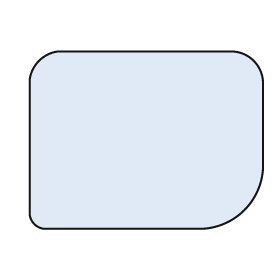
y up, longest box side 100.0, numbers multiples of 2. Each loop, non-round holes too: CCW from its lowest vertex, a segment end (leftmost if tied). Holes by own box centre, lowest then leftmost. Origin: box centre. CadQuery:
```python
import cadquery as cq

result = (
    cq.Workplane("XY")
    .moveTo(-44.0, -38.0)
    .lineTo(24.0, -38.0)
    .threePointArc((42.0, -30.0), (50.0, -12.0))
    .lineTo(50.0, 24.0)
    .threePointArc((46.0, 34.0), (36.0, 38.0))
    .lineTo(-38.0, 38.0)
    .threePointArc((-46.0, 34.0), (-50.0, 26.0))
    .lineTo(-50.0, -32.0)
    .threePointArc((-48.0, -36.0), (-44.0, -38.0))
    .close()
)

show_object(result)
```